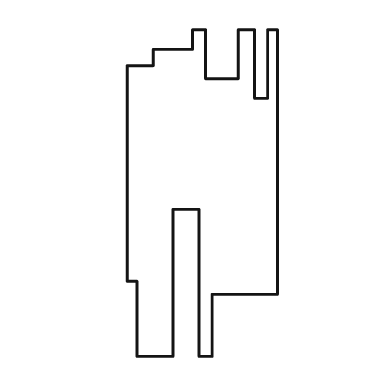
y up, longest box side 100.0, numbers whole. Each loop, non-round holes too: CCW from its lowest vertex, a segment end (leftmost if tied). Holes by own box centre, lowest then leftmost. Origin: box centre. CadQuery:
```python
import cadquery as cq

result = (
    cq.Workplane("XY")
    .moveTo(-20.0, -50.0)
    .lineTo(-9.0, -50.0)
    .lineTo(-9.0, -5.0)
    .lineTo(-1.0, -5.0)
    .lineTo(-1.0, -50.0)
    .lineTo(3.0, -50.0)
    .lineTo(3.0, -31.0)
    .lineTo(23.0, -31.0)
    .lineTo(23.0, 50.0)
    .lineTo(20.0, 50.0)
    .lineTo(20.0, 29.0)
    .lineTo(16.0, 29.0)
    .lineTo(16.0, 50.0)
    .lineTo(11.0, 50.0)
    .lineTo(11.0, 35.0)
    .lineTo(1.0, 35.0)
    .lineTo(1.0, 50.0)
    .lineTo(-3.0, 50.0)
    .lineTo(-3.0, 44.0)
    .lineTo(-15.0, 44.0)
    .lineTo(-15.0, 39.0)
    .lineTo(-23.0, 39.0)
    .lineTo(-23.0, -27.0)
    .lineTo(-20.0, -27.0)
    .close()
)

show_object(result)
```